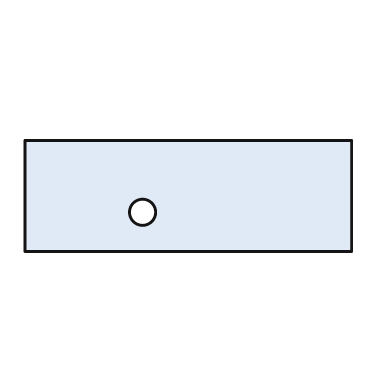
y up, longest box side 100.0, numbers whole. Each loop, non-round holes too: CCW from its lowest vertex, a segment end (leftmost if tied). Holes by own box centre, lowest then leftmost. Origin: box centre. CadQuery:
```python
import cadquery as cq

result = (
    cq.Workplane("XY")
    .moveTo(-50.0, -17.0)
    .lineTo(50.0, -17.0)
    .lineTo(50.0, 17.0)
    .lineTo(-50.0, 17.0)
    .close()
    .moveTo(-14.0, -5.0)
    .circle(4.0)
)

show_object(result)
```